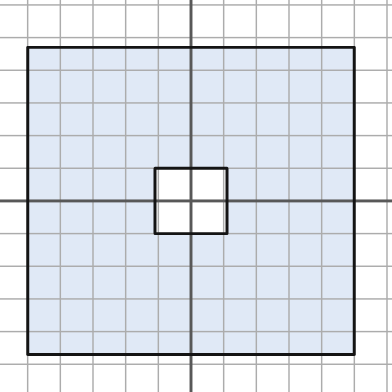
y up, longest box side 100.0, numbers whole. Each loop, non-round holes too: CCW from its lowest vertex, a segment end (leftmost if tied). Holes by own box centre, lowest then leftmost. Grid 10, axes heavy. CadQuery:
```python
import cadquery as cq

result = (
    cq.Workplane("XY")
    .moveTo(-50.0, -47.0)
    .lineTo(50.0, -47.0)
    .lineTo(50.0, 47.0)
    .lineTo(-50.0, 47.0)
    .close()
    .moveTo(-11.0, -10.0)
    .lineTo(11.0, -10.0)
    .lineTo(11.0, 10.0)
    .lineTo(-11.0, 10.0)
    .close()
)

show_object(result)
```